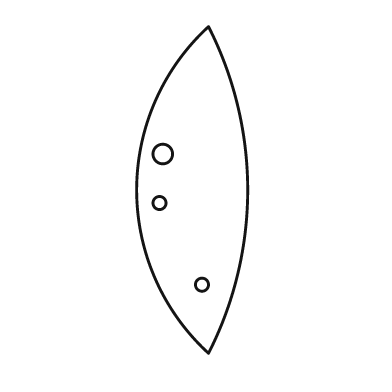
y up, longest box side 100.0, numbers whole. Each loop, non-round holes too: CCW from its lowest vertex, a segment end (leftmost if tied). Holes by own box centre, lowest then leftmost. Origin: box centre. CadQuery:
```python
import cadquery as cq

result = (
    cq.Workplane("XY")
    .moveTo(5.0, -50.0)
    .threePointArc((17.0, 0.0), (5.0, 50.0))
    .threePointArc((-17.0, 0.0), (5.0, -50.0))
    .close()
    .moveTo(3.0, -29.0)
    .circle(2.0)
    .moveTo(-10.0, -4.0)
    .circle(2.0)
    .moveTo(-9.0, 11.0)
    .circle(3.0)
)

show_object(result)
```